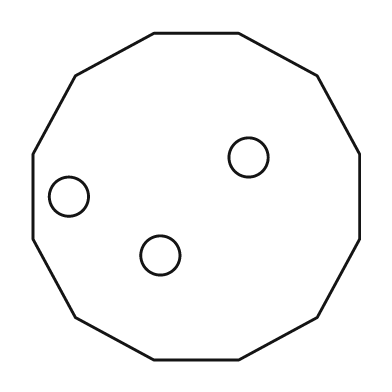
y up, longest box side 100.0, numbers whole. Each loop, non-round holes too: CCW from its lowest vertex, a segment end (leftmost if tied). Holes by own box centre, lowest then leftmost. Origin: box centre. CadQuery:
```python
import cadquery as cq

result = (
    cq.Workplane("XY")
    .moveTo(-13.0, -50.0)
    .lineTo(13.0, -50.0)
    .lineTo(37.0, -37.0)
    .lineTo(50.0, -13.0)
    .lineTo(50.0, 13.0)
    .lineTo(37.0, 37.0)
    .lineTo(13.0, 50.0)
    .lineTo(-13.0, 50.0)
    .lineTo(-37.0, 37.0)
    .lineTo(-50.0, 13.0)
    .lineTo(-50.0, -13.0)
    .lineTo(-37.0, -37.0)
    .close()
    .moveTo(-11.0, -18.0)
    .circle(6.0)
    .moveTo(-39.0, 0.0)
    .circle(6.0)
    .moveTo(16.0, 12.0)
    .circle(6.0)
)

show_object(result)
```